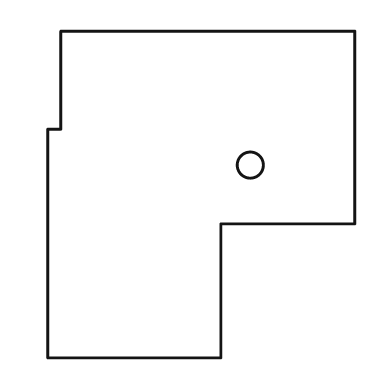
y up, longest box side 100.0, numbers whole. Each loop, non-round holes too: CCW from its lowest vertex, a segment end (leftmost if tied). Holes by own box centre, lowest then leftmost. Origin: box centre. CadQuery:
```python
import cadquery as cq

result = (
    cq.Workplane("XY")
    .moveTo(-47.0, -50.0)
    .lineTo(6.0, -50.0)
    .lineTo(6.0, -9.0)
    .lineTo(47.0, -9.0)
    .lineTo(47.0, 50.0)
    .lineTo(-43.0, 50.0)
    .lineTo(-43.0, 20.0)
    .lineTo(-47.0, 20.0)
    .close()
    .moveTo(15.0, 9.0)
    .circle(4.0)
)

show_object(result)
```